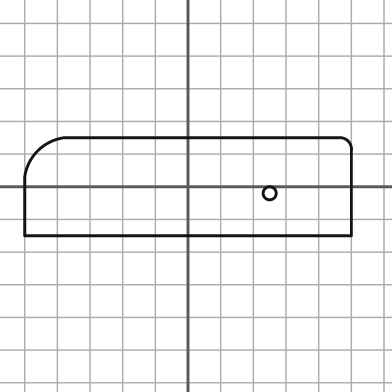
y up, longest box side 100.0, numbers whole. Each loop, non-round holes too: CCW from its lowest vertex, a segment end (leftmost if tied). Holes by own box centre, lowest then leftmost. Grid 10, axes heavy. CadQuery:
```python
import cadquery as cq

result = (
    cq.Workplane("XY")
    .moveTo(-50.0, -15.0)
    .lineTo(50.0, -15.0)
    .lineTo(50.0, 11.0)
    .threePointArc((49.0, 14.0), (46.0, 15.0))
    .lineTo(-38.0, 15.0)
    .threePointArc((-46.0, 11.0), (-50.0, 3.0))
    .close()
    .moveTo(25.0, -2.0)
    .circle(2.0)
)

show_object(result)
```